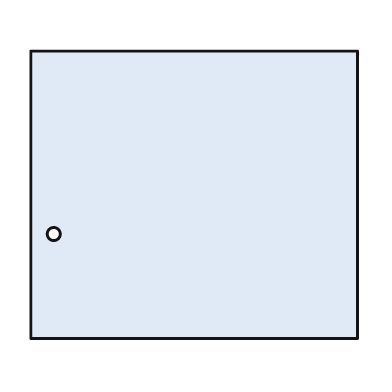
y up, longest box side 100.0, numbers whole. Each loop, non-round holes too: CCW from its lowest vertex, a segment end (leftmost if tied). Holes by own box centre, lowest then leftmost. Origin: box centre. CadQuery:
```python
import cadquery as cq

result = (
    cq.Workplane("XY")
    .moveTo(-50.0, -44.0)
    .lineTo(50.0, -44.0)
    .lineTo(50.0, 44.0)
    .lineTo(-50.0, 44.0)
    .close()
    .moveTo(-43.0, -12.0)
    .circle(2.0)
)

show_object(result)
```